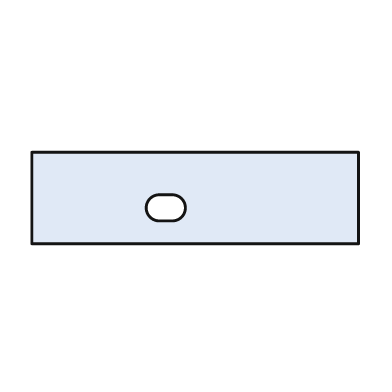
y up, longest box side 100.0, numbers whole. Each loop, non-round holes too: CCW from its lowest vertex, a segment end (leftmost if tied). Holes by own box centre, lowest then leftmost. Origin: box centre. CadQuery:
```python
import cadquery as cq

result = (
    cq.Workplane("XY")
    .moveTo(-50.0, -14.0)
    .lineTo(50.0, -14.0)
    .lineTo(50.0, 14.0)
    .lineTo(-50.0, 14.0)
    .close()
    .moveTo(-11.0, -7.0)
    .lineTo(-7.0, -7.0)
    .threePointArc((-3.0, -3.0), (-7.0, 1.0))
    .lineTo(-11.0, 1.0)
    .threePointArc((-15.0, -3.0), (-11.0, -7.0))
    .close()
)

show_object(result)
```